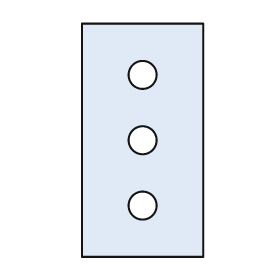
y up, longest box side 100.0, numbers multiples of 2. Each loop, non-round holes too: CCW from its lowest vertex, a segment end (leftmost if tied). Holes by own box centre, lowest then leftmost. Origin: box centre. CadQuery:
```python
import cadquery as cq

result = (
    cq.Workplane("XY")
    .moveTo(-26.0, -50.0)
    .lineTo(26.0, -50.0)
    .lineTo(26.0, 50.0)
    .lineTo(-26.0, 50.0)
    .close()
    .moveTo(0.0, -28.0)
    .circle(6.0)
    .moveTo(0.0, 0.0)
    .circle(6.0)
    .moveTo(0.0, 28.0)
    .circle(6.0)
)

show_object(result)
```